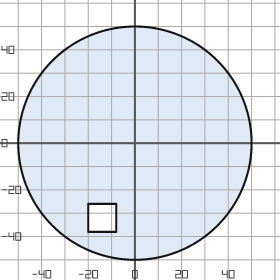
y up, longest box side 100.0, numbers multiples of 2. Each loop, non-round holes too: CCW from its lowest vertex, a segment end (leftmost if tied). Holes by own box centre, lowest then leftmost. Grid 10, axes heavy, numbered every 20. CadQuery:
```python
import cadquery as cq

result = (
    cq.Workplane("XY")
    .moveTo(0.0, 0.0)
    .circle(50.0)
    .moveTo(-20.0, -38.0)
    .lineTo(-8.0, -38.0)
    .lineTo(-8.0, -26.0)
    .lineTo(-20.0, -26.0)
    .close()
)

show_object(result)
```